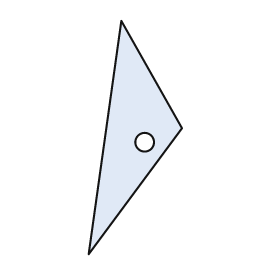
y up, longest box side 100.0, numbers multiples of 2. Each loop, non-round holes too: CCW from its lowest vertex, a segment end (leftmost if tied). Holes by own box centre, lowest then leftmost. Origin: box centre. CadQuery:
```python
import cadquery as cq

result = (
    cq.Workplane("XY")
    .moveTo(-20.0, -50.0)
    .lineTo(20.0, 4.0)
    .lineTo(-6.0, 50.0)
    .close()
    .moveTo(4.0, -2.0)
    .circle(4.0)
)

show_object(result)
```